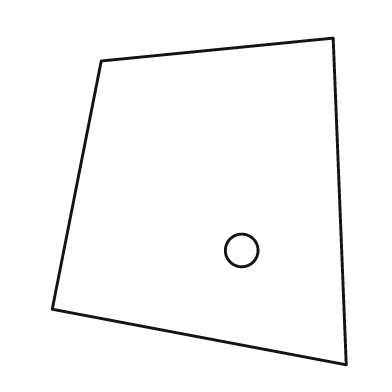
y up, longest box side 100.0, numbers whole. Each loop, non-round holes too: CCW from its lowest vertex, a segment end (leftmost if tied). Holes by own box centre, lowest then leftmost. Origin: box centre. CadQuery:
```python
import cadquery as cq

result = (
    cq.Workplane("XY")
    .moveTo(45.0, -50.0)
    .lineTo(41.0, 50.0)
    .lineTo(-30.0, 43.0)
    .lineTo(-45.0, -33.0)
    .close()
    .moveTo(13.0, -15.0)
    .circle(5.0)
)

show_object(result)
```